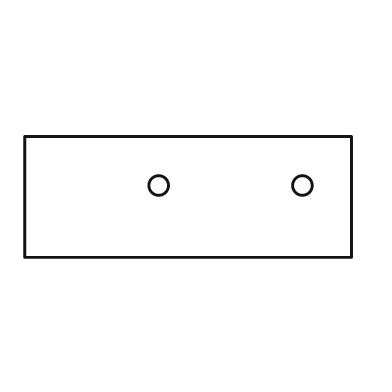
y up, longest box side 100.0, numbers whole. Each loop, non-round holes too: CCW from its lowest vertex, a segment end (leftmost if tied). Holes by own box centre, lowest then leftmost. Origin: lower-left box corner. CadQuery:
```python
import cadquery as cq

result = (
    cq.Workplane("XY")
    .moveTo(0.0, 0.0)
    .lineTo(100.0, 0.0)
    .lineTo(100.0, 37.0)
    .lineTo(0.0, 37.0)
    .close()
    .moveTo(41.0, 22.0)
    .circle(3.0)
    .moveTo(85.0, 22.0)
    .circle(3.0)
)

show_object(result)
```